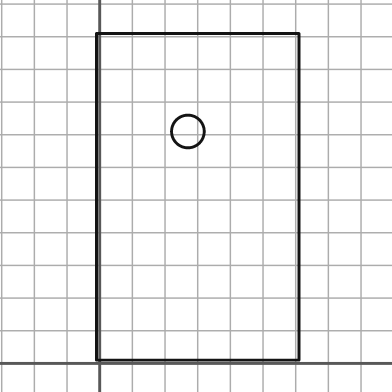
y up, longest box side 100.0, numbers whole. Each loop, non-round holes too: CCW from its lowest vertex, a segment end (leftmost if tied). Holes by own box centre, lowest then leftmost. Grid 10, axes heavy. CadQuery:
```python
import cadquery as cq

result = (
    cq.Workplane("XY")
    .moveTo(-1.0, 1.0)
    .lineTo(61.0, 1.0)
    .lineTo(61.0, 101.0)
    .lineTo(-1.0, 101.0)
    .close()
    .moveTo(27.0, 71.0)
    .circle(5.0)
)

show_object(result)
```